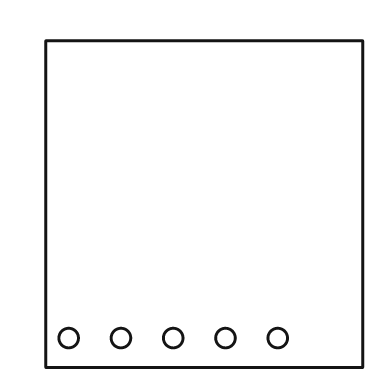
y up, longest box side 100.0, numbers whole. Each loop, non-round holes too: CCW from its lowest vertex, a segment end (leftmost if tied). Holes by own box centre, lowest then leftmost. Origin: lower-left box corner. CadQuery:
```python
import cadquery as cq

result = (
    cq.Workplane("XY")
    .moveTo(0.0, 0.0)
    .lineTo(97.0, 0.0)
    .lineTo(97.0, 100.0)
    .lineTo(0.0, 100.0)
    .close()
    .moveTo(7.0, 9.0)
    .circle(3.0)
    .moveTo(23.0, 9.0)
    .circle(3.0)
    .moveTo(39.0, 9.0)
    .circle(3.0)
    .moveTo(55.0, 9.0)
    .circle(3.0)
    .moveTo(71.0, 9.0)
    .circle(3.0)
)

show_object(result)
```